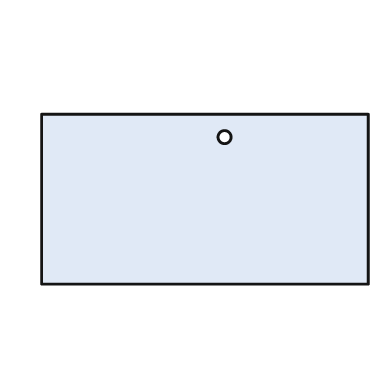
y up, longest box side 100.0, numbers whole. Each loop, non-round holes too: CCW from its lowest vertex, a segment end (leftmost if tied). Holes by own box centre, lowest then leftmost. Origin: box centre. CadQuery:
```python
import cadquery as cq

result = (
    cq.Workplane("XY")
    .moveTo(-50.0, -26.0)
    .lineTo(50.0, -26.0)
    .lineTo(50.0, 26.0)
    .lineTo(-50.0, 26.0)
    .close()
    .moveTo(6.0, 19.0)
    .circle(2.0)
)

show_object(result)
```